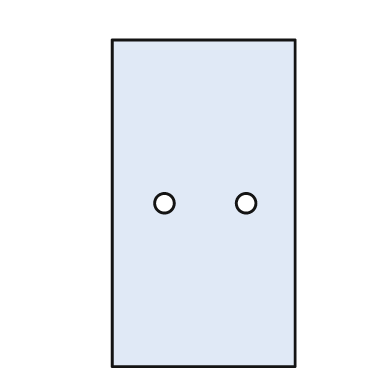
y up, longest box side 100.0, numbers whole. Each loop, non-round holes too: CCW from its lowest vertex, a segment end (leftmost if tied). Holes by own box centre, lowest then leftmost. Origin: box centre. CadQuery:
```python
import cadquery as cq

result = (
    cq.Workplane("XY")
    .moveTo(-28.0, -50.0)
    .lineTo(28.0, -50.0)
    .lineTo(28.0, 50.0)
    .lineTo(-28.0, 50.0)
    .close()
    .moveTo(-12.0, 0.0)
    .circle(3.0)
    .moveTo(13.0, 0.0)
    .circle(3.0)
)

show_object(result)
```